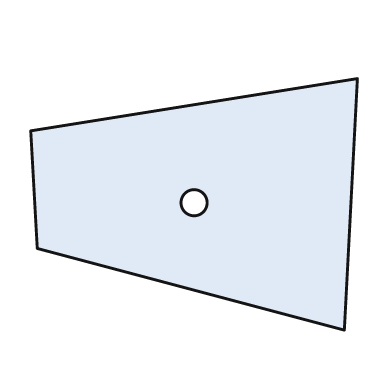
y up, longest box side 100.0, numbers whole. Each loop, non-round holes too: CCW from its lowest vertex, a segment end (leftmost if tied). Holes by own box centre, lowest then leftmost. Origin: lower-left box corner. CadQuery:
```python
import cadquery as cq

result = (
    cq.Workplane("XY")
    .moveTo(96.0, 0.0)
    .lineTo(100.0, 77.0)
    .lineTo(0.0, 61.0)
    .lineTo(2.0, 25.0)
    .close()
    .moveTo(50.0, 39.0)
    .circle(4.0)
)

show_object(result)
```